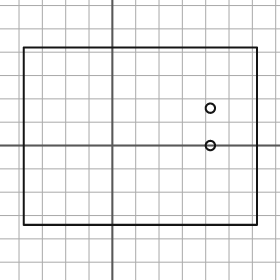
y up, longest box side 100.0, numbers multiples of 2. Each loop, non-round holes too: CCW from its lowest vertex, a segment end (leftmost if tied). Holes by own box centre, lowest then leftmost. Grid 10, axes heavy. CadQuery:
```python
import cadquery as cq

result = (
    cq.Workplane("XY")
    .moveTo(-38.0, -34.0)
    .lineTo(62.0, -34.0)
    .lineTo(62.0, 42.0)
    .lineTo(-38.0, 42.0)
    .close()
    .moveTo(42.0, 0.0)
    .circle(2.0)
    .moveTo(42.0, 16.0)
    .circle(2.0)
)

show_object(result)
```